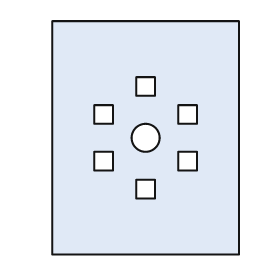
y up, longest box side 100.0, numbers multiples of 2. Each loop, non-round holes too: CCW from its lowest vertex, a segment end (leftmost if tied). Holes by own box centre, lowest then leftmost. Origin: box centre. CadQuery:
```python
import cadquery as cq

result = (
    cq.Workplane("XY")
    .moveTo(-40.0, -50.0)
    .lineTo(40.0, -50.0)
    .lineTo(40.0, 50.0)
    .lineTo(-40.0, 50.0)
    .close()
    .moveTo(-4.0, -26.0)
    .lineTo(4.0, -26.0)
    .lineTo(4.0, -18.0)
    .lineTo(-4.0, -18.0)
    .close()
    .moveTo(-22.0, -14.0)
    .lineTo(-14.0, -14.0)
    .lineTo(-14.0, -6.0)
    .lineTo(-22.0, -6.0)
    .close()
    .moveTo(14.0, -14.0)
    .lineTo(22.0, -14.0)
    .lineTo(22.0, -6.0)
    .lineTo(14.0, -6.0)
    .close()
    .moveTo(0.0, 0.0)
    .circle(6.0)
    .moveTo(-22.0, 6.0)
    .lineTo(-14.0, 6.0)
    .lineTo(-14.0, 14.0)
    .lineTo(-22.0, 14.0)
    .close()
    .moveTo(14.0, 6.0)
    .lineTo(22.0, 6.0)
    .lineTo(22.0, 14.0)
    .lineTo(14.0, 14.0)
    .close()
    .moveTo(-4.0, 18.0)
    .lineTo(4.0, 18.0)
    .lineTo(4.0, 26.0)
    .lineTo(-4.0, 26.0)
    .close()
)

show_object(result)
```